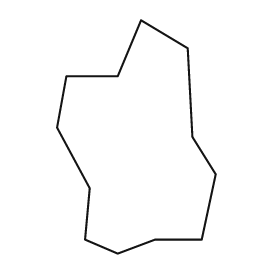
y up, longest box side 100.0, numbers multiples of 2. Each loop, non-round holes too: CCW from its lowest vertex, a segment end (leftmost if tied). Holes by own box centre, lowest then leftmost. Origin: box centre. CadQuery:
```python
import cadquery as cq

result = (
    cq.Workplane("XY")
    .moveTo(-8.0, -50.0)
    .lineTo(8.0, -44.0)
    .lineTo(28.0, -44.0)
    .lineTo(34.0, -16.0)
    .lineTo(24.0, 0.0)
    .lineTo(22.0, 38.0)
    .lineTo(2.0, 50.0)
    .lineTo(-8.0, 26.0)
    .lineTo(-30.0, 26.0)
    .lineTo(-34.0, 4.0)
    .lineTo(-20.0, -22.0)
    .lineTo(-22.0, -44.0)
    .close()
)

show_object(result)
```